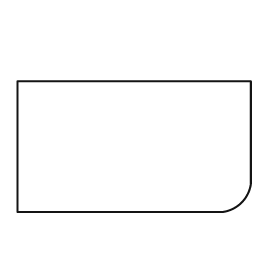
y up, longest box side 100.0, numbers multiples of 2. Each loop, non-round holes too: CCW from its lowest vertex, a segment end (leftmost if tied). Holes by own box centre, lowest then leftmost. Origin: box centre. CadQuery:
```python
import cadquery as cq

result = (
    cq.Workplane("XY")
    .moveTo(-50.0, -28.0)
    .lineTo(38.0, -28.0)
    .threePointArc((46.0, -24.0), (50.0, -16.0))
    .lineTo(50.0, 28.0)
    .lineTo(-50.0, 28.0)
    .close()
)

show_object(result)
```